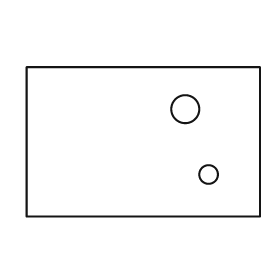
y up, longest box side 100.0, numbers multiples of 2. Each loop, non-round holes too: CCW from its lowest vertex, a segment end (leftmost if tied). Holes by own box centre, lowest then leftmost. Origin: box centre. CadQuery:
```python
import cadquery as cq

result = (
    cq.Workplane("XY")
    .moveTo(-50.0, -32.0)
    .lineTo(50.0, -32.0)
    .lineTo(50.0, 32.0)
    .lineTo(-50.0, 32.0)
    .close()
    .moveTo(28.0, -14.0)
    .circle(4.0)
    .moveTo(18.0, 14.0)
    .circle(6.0)
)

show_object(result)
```